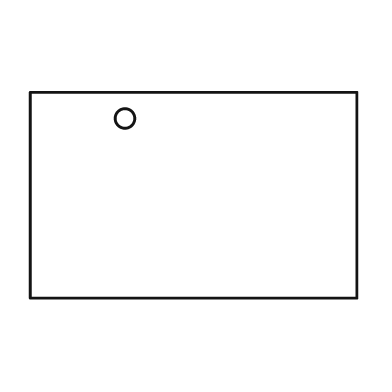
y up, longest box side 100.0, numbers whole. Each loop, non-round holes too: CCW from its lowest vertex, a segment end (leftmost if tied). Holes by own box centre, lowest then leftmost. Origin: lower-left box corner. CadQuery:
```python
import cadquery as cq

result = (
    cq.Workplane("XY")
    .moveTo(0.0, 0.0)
    .lineTo(100.0, 0.0)
    .lineTo(100.0, 63.0)
    .lineTo(0.0, 63.0)
    .close()
    .moveTo(29.0, 55.0)
    .circle(3.0)
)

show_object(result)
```